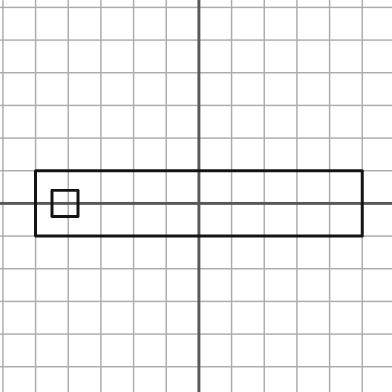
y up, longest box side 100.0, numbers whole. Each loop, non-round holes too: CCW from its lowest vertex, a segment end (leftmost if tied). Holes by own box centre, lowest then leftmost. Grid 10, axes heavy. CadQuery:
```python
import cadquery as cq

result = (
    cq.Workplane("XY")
    .moveTo(-50.0, -10.0)
    .lineTo(50.0, -10.0)
    .lineTo(50.0, 10.0)
    .lineTo(-50.0, 10.0)
    .close()
    .moveTo(-45.0, -4.0)
    .lineTo(-37.0, -4.0)
    .lineTo(-37.0, 4.0)
    .lineTo(-45.0, 4.0)
    .close()
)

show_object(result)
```